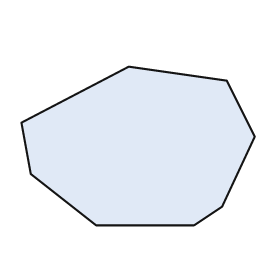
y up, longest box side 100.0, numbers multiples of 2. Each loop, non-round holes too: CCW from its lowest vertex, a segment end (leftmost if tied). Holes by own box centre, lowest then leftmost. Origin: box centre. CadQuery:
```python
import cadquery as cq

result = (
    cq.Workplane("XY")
    .moveTo(-18.0, -34.0)
    .lineTo(24.0, -34.0)
    .lineTo(36.0, -26.0)
    .lineTo(50.0, 4.0)
    .lineTo(38.0, 28.0)
    .lineTo(-4.0, 34.0)
    .lineTo(-50.0, 10.0)
    .lineTo(-46.0, -12.0)
    .close()
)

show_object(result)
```